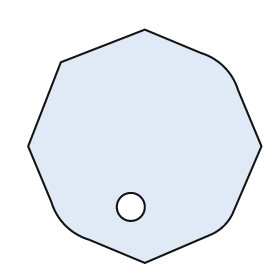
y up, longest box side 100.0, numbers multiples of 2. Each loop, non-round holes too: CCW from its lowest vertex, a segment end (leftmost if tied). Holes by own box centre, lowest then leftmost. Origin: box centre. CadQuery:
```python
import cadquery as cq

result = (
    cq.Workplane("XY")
    .moveTo(0.0, -50.0)
    .lineTo(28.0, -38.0)
    .threePointArc((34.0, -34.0), (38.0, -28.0))
    .lineTo(50.0, 0.0)
    .lineTo(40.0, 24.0)
    .threePointArc((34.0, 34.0), (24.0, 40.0))
    .lineTo(0.0, 50.0)
    .lineTo(-36.0, 36.0)
    .lineTo(-50.0, 0.0)
    .lineTo(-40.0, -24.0)
    .threePointArc((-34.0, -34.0), (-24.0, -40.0))
    .close()
    .moveTo(-6.0, -26.0)
    .circle(6.0)
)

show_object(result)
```